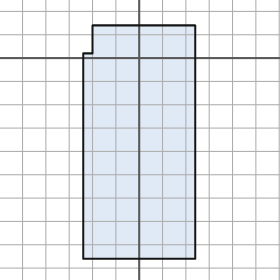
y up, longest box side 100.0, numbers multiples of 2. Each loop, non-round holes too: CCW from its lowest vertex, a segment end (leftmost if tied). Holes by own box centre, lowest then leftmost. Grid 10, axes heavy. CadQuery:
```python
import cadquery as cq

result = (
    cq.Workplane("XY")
    .moveTo(-24.0, -86.0)
    .lineTo(24.0, -86.0)
    .lineTo(24.0, 14.0)
    .lineTo(-20.0, 14.0)
    .lineTo(-20.0, 2.0)
    .lineTo(-24.0, 2.0)
    .close()
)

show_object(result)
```